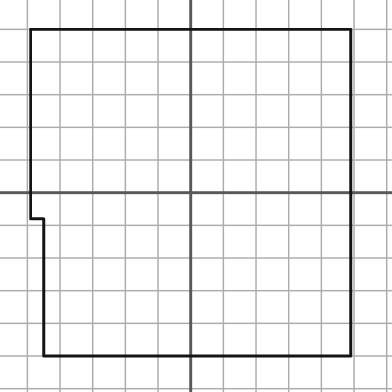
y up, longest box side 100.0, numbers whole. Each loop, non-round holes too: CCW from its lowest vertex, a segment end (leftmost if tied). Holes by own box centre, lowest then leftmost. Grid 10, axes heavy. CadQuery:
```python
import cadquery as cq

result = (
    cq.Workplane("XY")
    .moveTo(-45.0, -50.0)
    .lineTo(49.0, -50.0)
    .lineTo(49.0, 50.0)
    .lineTo(-49.0, 50.0)
    .lineTo(-49.0, -8.0)
    .lineTo(-45.0, -8.0)
    .close()
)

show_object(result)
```